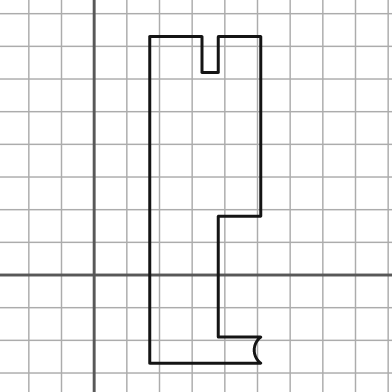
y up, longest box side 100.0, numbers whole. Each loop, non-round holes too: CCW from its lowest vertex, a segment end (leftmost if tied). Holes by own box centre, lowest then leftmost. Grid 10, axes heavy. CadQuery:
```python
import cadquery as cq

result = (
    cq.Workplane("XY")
    .moveTo(17.0, -27.0)
    .lineTo(51.0, -27.0)
    .threePointArc((49.0, -23.0), (51.0, -19.0))
    .lineTo(38.0, -19.0)
    .lineTo(38.0, 18.0)
    .lineTo(51.0, 18.0)
    .lineTo(51.0, 73.0)
    .lineTo(38.0, 73.0)
    .lineTo(38.0, 62.0)
    .lineTo(33.0, 62.0)
    .lineTo(33.0, 73.0)
    .lineTo(17.0, 73.0)
    .close()
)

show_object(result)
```